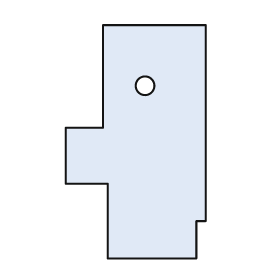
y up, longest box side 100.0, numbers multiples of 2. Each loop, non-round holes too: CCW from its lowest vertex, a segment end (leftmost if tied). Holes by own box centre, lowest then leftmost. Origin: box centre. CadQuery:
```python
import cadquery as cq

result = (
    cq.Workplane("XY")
    .moveTo(-12.0, -50.0)
    .lineTo(26.0, -50.0)
    .lineTo(26.0, -34.0)
    .lineTo(30.0, -34.0)
    .lineTo(30.0, 50.0)
    .lineTo(-14.0, 50.0)
    .lineTo(-14.0, 6.0)
    .lineTo(-30.0, 6.0)
    .lineTo(-30.0, -18.0)
    .lineTo(-12.0, -18.0)
    .close()
    .moveTo(4.0, 24.0)
    .circle(4.0)
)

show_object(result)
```